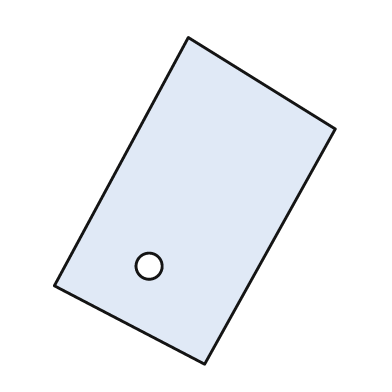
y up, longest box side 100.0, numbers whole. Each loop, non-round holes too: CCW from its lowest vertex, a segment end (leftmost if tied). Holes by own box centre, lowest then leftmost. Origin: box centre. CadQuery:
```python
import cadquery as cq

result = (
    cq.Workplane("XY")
    .moveTo(3.0, -50.0)
    .lineTo(43.0, 22.0)
    .lineTo(-2.0, 50.0)
    .lineTo(-43.0, -26.0)
    .close()
    .moveTo(-14.0, -20.0)
    .circle(4.0)
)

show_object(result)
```